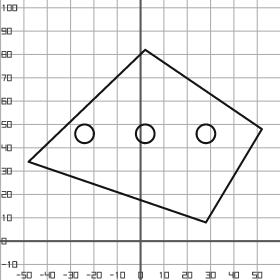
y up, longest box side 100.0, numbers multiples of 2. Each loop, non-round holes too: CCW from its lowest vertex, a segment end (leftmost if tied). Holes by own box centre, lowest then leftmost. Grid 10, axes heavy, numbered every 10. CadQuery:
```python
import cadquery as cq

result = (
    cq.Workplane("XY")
    .moveTo(28.0, 8.0)
    .lineTo(52.0, 48.0)
    .lineTo(2.0, 82.0)
    .lineTo(-48.0, 34.0)
    .close()
    .moveTo(-24.0, 46.0)
    .circle(4.0)
    .moveTo(2.0, 46.0)
    .circle(4.0)
    .moveTo(28.0, 46.0)
    .circle(4.0)
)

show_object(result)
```